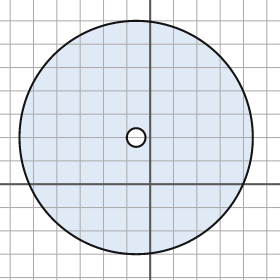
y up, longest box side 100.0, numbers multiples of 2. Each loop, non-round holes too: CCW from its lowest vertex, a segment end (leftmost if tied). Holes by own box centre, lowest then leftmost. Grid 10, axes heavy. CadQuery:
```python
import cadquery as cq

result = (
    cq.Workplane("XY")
    .moveTo(-6.0, 20.0)
    .circle(50.0)
    .moveTo(-6.0, 20.0)
    .circle(4.0)
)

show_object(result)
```